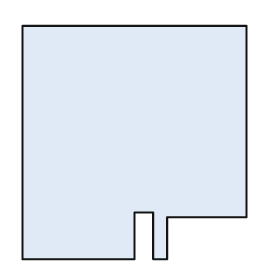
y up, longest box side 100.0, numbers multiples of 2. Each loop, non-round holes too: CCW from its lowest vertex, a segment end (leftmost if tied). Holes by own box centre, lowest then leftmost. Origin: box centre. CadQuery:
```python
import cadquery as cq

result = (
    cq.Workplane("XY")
    .moveTo(-48.0, -50.0)
    .lineTo(0.0, -50.0)
    .lineTo(0.0, -30.0)
    .lineTo(8.0, -30.0)
    .lineTo(8.0, -50.0)
    .lineTo(14.0, -50.0)
    .lineTo(14.0, -32.0)
    .lineTo(48.0, -32.0)
    .lineTo(48.0, 50.0)
    .lineTo(-48.0, 50.0)
    .close()
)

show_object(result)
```